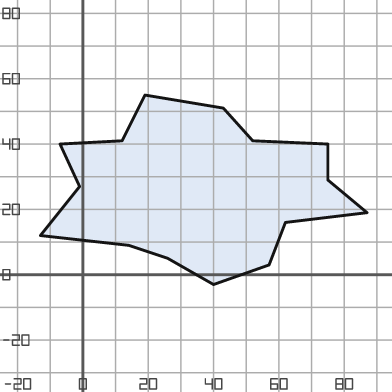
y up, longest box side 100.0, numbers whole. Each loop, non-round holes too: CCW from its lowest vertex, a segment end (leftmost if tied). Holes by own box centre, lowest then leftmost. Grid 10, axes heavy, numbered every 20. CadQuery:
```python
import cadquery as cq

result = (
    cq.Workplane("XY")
    .moveTo(40.0, -3.0)
    .lineTo(57.0, 3.0)
    .lineTo(62.0, 16.0)
    .lineTo(87.0, 19.0)
    .lineTo(75.0, 29.0)
    .lineTo(75.0, 40.0)
    .lineTo(52.0, 41.0)
    .lineTo(43.0, 51.0)
    .lineTo(19.0, 55.0)
    .lineTo(12.0, 41.0)
    .lineTo(-7.0, 40.0)
    .lineTo(-1.0, 27.0)
    .lineTo(-13.0, 12.0)
    .lineTo(14.0, 9.0)
    .lineTo(26.0, 5.0)
    .close()
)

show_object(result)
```